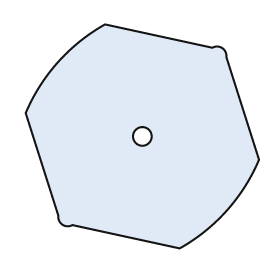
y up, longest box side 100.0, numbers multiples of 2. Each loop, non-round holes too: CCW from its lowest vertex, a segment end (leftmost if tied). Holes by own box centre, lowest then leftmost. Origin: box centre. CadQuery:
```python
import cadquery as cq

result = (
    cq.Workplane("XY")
    .moveTo(16.0, -48.0)
    .threePointArc((36.0, -32.0), (50.0, -10.0))
    .lineTo(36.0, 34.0)
    .threePointArc((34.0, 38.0), (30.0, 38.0))
    .lineTo(-16.0, 48.0)
    .threePointArc((-36.0, 32.0), (-50.0, 10.0))
    .lineTo(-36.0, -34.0)
    .threePointArc((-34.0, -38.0), (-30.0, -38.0))
    .close()
    .moveTo(0.0, 0.0)
    .circle(4.0)
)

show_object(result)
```